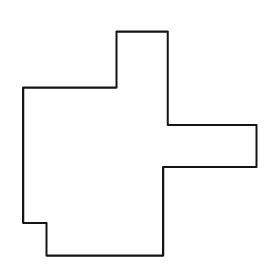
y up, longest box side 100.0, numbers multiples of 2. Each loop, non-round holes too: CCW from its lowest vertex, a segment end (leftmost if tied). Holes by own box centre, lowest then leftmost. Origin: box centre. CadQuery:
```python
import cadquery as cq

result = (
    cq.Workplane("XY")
    .moveTo(-40.0, -48.0)
    .lineTo(10.0, -48.0)
    .lineTo(10.0, -10.0)
    .lineTo(50.0, -10.0)
    .lineTo(50.0, 8.0)
    .lineTo(12.0, 8.0)
    .lineTo(12.0, 48.0)
    .lineTo(-10.0, 48.0)
    .lineTo(-10.0, 24.0)
    .lineTo(-50.0, 24.0)
    .lineTo(-50.0, -34.0)
    .lineTo(-40.0, -34.0)
    .close()
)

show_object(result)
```